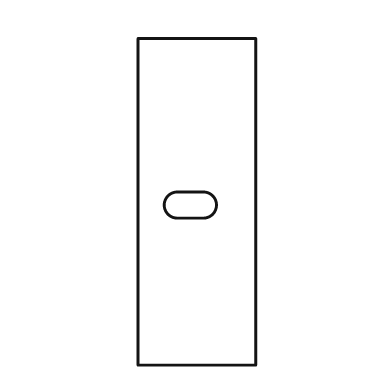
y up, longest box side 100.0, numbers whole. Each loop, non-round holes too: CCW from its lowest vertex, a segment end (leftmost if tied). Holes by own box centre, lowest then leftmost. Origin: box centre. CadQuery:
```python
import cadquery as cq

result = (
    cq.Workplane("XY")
    .moveTo(-18.0, -50.0)
    .lineTo(18.0, -50.0)
    .lineTo(18.0, 50.0)
    .lineTo(-18.0, 50.0)
    .close()
    .moveTo(-6.0, -5.0)
    .lineTo(2.0, -5.0)
    .threePointArc((6.0, -1.0), (2.0, 3.0))
    .lineTo(-6.0, 3.0)
    .threePointArc((-10.0, -1.0), (-6.0, -5.0))
    .close()
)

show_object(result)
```